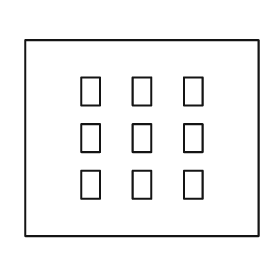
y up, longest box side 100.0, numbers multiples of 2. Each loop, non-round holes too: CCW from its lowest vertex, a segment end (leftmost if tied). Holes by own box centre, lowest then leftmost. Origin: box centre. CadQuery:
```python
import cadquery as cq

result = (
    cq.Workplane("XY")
    .moveTo(-50.0, -42.0)
    .lineTo(50.0, -42.0)
    .lineTo(50.0, 42.0)
    .lineTo(-50.0, 42.0)
    .close()
    .moveTo(-26.0, -26.0)
    .lineTo(-18.0, -26.0)
    .lineTo(-18.0, -14.0)
    .lineTo(-26.0, -14.0)
    .close()
    .moveTo(-4.0, -26.0)
    .lineTo(4.0, -26.0)
    .lineTo(4.0, -14.0)
    .lineTo(-4.0, -14.0)
    .close()
    .moveTo(18.0, -26.0)
    .lineTo(26.0, -26.0)
    .lineTo(26.0, -14.0)
    .lineTo(18.0, -14.0)
    .close()
    .moveTo(-26.0, -6.0)
    .lineTo(-18.0, -6.0)
    .lineTo(-18.0, 6.0)
    .lineTo(-26.0, 6.0)
    .close()
    .moveTo(-4.0, -6.0)
    .lineTo(4.0, -6.0)
    .lineTo(4.0, 6.0)
    .lineTo(-4.0, 6.0)
    .close()
    .moveTo(18.0, -6.0)
    .lineTo(26.0, -6.0)
    .lineTo(26.0, 6.0)
    .lineTo(18.0, 6.0)
    .close()
    .moveTo(-26.0, 14.0)
    .lineTo(-18.0, 14.0)
    .lineTo(-18.0, 26.0)
    .lineTo(-26.0, 26.0)
    .close()
    .moveTo(-4.0, 14.0)
    .lineTo(4.0, 14.0)
    .lineTo(4.0, 26.0)
    .lineTo(-4.0, 26.0)
    .close()
    .moveTo(18.0, 14.0)
    .lineTo(26.0, 14.0)
    .lineTo(26.0, 26.0)
    .lineTo(18.0, 26.0)
    .close()
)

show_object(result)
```